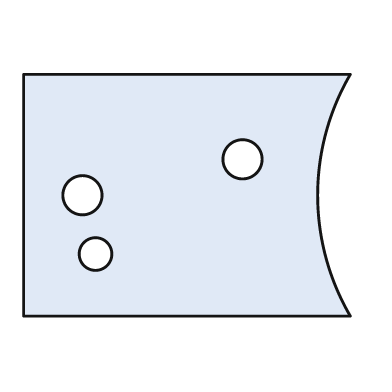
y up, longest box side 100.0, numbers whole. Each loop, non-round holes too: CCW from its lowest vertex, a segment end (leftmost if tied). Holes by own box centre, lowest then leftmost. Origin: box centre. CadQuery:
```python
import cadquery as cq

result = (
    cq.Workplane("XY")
    .moveTo(-50.0, -37.0)
    .lineTo(50.0, -37.0)
    .threePointArc((40.0, 0.0), (50.0, 37.0))
    .lineTo(-50.0, 37.0)
    .close()
    .moveTo(-28.0, -18.0)
    .circle(5.0)
    .moveTo(-32.0, 0.0)
    .circle(6.0)
    .moveTo(17.0, 11.0)
    .circle(6.0)
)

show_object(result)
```